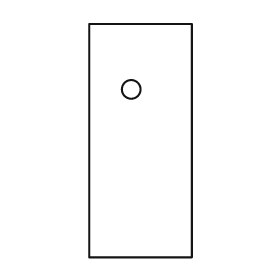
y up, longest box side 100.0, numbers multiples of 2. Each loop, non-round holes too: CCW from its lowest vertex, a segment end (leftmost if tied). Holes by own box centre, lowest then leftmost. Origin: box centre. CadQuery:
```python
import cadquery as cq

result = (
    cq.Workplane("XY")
    .moveTo(-22.0, -50.0)
    .lineTo(22.0, -50.0)
    .lineTo(22.0, 50.0)
    .lineTo(-22.0, 50.0)
    .close()
    .moveTo(-4.0, 22.0)
    .circle(4.0)
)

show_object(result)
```